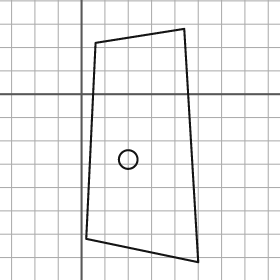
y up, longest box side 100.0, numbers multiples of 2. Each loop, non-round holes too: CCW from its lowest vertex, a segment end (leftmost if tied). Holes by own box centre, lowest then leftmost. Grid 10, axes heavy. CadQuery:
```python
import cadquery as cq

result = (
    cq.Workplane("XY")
    .moveTo(50.0, -72.0)
    .lineTo(44.0, 28.0)
    .lineTo(6.0, 22.0)
    .lineTo(2.0, -62.0)
    .close()
    .moveTo(20.0, -28.0)
    .circle(4.0)
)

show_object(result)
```